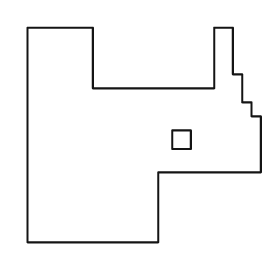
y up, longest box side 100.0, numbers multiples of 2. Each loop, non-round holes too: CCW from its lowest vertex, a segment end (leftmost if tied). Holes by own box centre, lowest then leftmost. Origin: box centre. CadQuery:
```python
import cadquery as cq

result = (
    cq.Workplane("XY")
    .moveTo(-50.0, -46.0)
    .lineTo(6.0, -46.0)
    .lineTo(6.0, -16.0)
    .lineTo(50.0, -16.0)
    .lineTo(50.0, 8.0)
    .lineTo(46.0, 8.0)
    .lineTo(46.0, 14.0)
    .lineTo(42.0, 14.0)
    .lineTo(42.0, 26.0)
    .lineTo(38.0, 26.0)
    .lineTo(38.0, 46.0)
    .lineTo(30.0, 46.0)
    .lineTo(30.0, 20.0)
    .lineTo(-22.0, 20.0)
    .lineTo(-22.0, 46.0)
    .lineTo(-50.0, 46.0)
    .close()
    .moveTo(12.0, -6.0)
    .lineTo(20.0, -6.0)
    .lineTo(20.0, 2.0)
    .lineTo(12.0, 2.0)
    .close()
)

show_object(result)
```